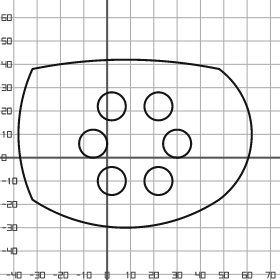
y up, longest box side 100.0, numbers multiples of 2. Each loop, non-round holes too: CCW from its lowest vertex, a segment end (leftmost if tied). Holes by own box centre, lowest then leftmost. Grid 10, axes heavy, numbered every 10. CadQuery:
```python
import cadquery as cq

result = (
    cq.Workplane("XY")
    .moveTo(-32.0, -18.0)
    .threePointArc((8.0, -30.0), (48.0, -18.0))
    .threePointArc((62.0, 10.0), (48.0, 38.0))
    .threePointArc((8.0, 42.0), (-32.0, 38.0))
    .threePointArc((-38.0, 10.0), (-32.0, -18.0))
    .close()
    .moveTo(2.0, -10.0)
    .circle(6.0)
    .moveTo(22.0, -10.0)
    .circle(6.0)
    .moveTo(-6.0, 6.0)
    .circle(6.0)
    .moveTo(30.0, 6.0)
    .circle(6.0)
    .moveTo(2.0, 22.0)
    .circle(6.0)
    .moveTo(22.0, 22.0)
    .circle(6.0)
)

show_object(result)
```